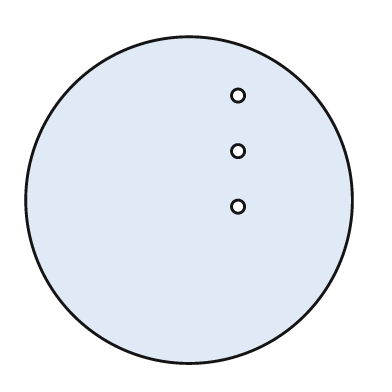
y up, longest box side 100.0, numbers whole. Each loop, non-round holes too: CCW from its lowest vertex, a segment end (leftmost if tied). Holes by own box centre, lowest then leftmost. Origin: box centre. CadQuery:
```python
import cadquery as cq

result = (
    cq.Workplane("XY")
    .moveTo(0.0, 0.0)
    .circle(50.0)
    .moveTo(15.0, -2.0)
    .circle(2.0)
    .moveTo(15.0, 15.0)
    .circle(2.0)
    .moveTo(15.0, 32.0)
    .circle(2.0)
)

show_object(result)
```